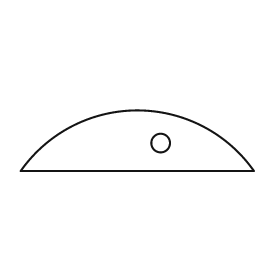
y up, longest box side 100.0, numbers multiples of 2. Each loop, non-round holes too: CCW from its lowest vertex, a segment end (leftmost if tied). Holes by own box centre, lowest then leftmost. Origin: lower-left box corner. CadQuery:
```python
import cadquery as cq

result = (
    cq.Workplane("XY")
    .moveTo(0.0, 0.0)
    .lineTo(100.0, 0.0)
    .threePointArc((50.0, 26.0), (0.0, 0.0))
    .close()
    .moveTo(60.0, 12.0)
    .circle(4.0)
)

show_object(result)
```